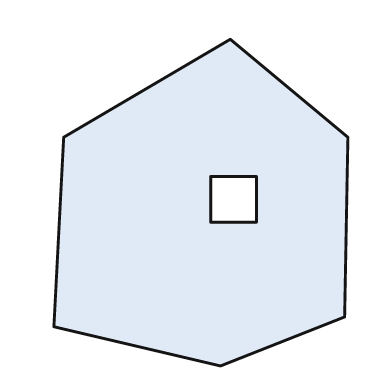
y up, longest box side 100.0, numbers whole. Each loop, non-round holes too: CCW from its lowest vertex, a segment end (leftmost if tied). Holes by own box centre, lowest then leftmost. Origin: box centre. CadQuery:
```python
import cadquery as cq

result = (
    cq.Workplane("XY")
    .moveTo(6.0, -50.0)
    .lineTo(44.0, -35.0)
    .lineTo(45.0, 20.0)
    .lineTo(9.0, 50.0)
    .lineTo(-42.0, 20.0)
    .lineTo(-45.0, -38.0)
    .close()
    .moveTo(3.0, -6.0)
    .lineTo(17.0, -6.0)
    .lineTo(17.0, 8.0)
    .lineTo(3.0, 8.0)
    .close()
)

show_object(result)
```